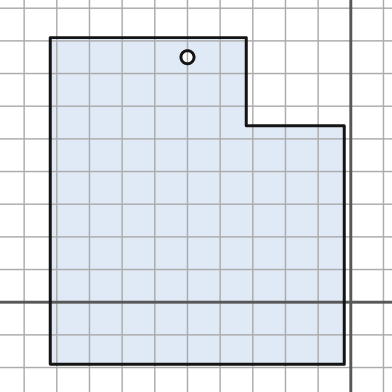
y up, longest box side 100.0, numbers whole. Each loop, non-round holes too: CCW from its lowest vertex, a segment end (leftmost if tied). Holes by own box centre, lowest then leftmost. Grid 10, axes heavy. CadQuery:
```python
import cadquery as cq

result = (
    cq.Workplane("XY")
    .moveTo(-92.0, -19.0)
    .lineTo(-2.0, -19.0)
    .lineTo(-2.0, 54.0)
    .lineTo(-32.0, 54.0)
    .lineTo(-32.0, 81.0)
    .lineTo(-92.0, 81.0)
    .close()
    .moveTo(-50.0, 75.0)
    .circle(2.0)
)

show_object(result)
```